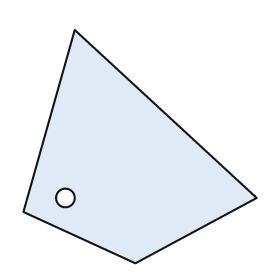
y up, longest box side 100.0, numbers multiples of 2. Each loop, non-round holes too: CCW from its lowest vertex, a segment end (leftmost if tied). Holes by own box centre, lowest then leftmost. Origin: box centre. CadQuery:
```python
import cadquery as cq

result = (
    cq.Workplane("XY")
    .moveTo(-2.0, -50.0)
    .lineTo(50.0, -22.0)
    .lineTo(-28.0, 50.0)
    .lineTo(-50.0, -28.0)
    .close()
    .moveTo(-32.0, -22.0)
    .circle(4.0)
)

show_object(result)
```